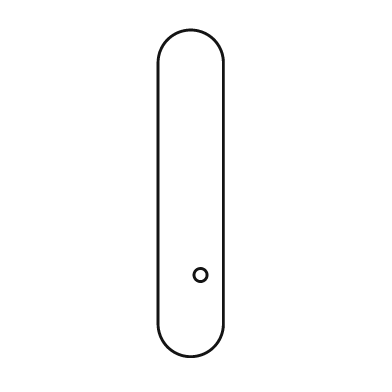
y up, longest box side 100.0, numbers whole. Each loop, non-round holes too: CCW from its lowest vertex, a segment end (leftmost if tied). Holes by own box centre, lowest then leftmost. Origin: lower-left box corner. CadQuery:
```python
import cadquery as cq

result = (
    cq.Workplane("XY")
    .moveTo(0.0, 10.0)
    .threePointArc((10.0, 0.0), (20.0, 10.0))
    .lineTo(20.0, 90.0)
    .threePointArc((10.0, 100.0), (0.0, 90.0))
    .close()
    .moveTo(13.0, 25.0)
    .circle(2.0)
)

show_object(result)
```